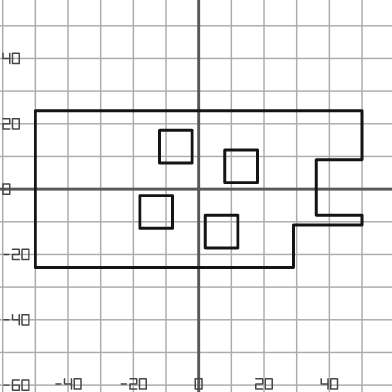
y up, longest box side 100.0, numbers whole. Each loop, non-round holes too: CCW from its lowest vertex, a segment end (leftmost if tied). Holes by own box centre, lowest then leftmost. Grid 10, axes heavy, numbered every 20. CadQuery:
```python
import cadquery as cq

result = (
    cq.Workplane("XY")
    .moveTo(-50.0, -24.0)
    .lineTo(29.0, -24.0)
    .lineTo(29.0, -11.0)
    .lineTo(50.0, -11.0)
    .lineTo(50.0, -8.0)
    .lineTo(36.0, -8.0)
    .lineTo(36.0, 9.0)
    .lineTo(50.0, 9.0)
    .lineTo(50.0, 24.0)
    .lineTo(-50.0, 24.0)
    .close()
    .moveTo(2.0, -18.0)
    .lineTo(12.0, -18.0)
    .lineTo(12.0, -8.0)
    .lineTo(2.0, -8.0)
    .close()
    .moveTo(-18.0, -12.0)
    .lineTo(-8.0, -12.0)
    .lineTo(-8.0, -2.0)
    .lineTo(-18.0, -2.0)
    .close()
    .moveTo(8.0, 2.0)
    .lineTo(18.0, 2.0)
    .lineTo(18.0, 12.0)
    .lineTo(8.0, 12.0)
    .close()
    .moveTo(-12.0, 8.0)
    .lineTo(-2.0, 8.0)
    .lineTo(-2.0, 18.0)
    .lineTo(-12.0, 18.0)
    .close()
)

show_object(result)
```